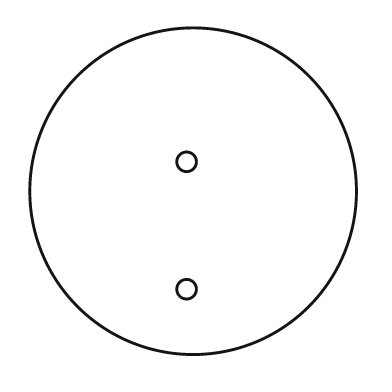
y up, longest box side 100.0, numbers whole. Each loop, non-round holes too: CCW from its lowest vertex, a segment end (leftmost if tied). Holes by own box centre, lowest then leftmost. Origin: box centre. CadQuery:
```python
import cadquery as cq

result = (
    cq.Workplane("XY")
    .moveTo(0.0, 0.0)
    .circle(50.0)
    .moveTo(-2.0, -30.0)
    .circle(3.0)
    .moveTo(-2.0, 9.0)
    .circle(3.0)
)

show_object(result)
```